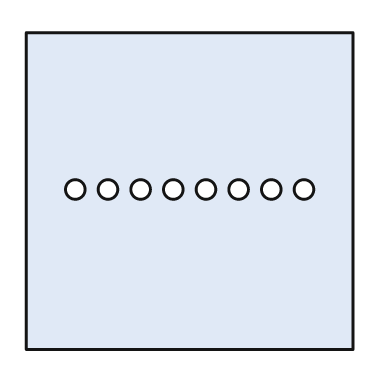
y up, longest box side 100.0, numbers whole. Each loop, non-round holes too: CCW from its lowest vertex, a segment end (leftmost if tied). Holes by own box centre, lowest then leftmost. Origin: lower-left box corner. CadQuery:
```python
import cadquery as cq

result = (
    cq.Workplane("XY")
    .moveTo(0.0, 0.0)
    .lineTo(100.0, 0.0)
    .lineTo(100.0, 97.0)
    .lineTo(0.0, 97.0)
    .close()
    .moveTo(15.0, 49.0)
    .circle(3.0)
    .moveTo(25.0, 49.0)
    .circle(3.0)
    .moveTo(35.0, 49.0)
    .circle(3.0)
    .moveTo(45.0, 49.0)
    .circle(3.0)
    .moveTo(55.0, 49.0)
    .circle(3.0)
    .moveTo(65.0, 49.0)
    .circle(3.0)
    .moveTo(75.0, 49.0)
    .circle(3.0)
    .moveTo(85.0, 49.0)
    .circle(3.0)
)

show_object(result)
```